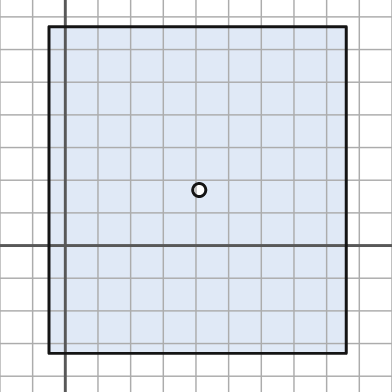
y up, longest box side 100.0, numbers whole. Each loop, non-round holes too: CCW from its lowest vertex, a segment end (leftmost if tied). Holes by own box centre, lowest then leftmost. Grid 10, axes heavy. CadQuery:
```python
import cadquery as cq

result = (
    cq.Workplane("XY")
    .moveTo(-5.0, -33.0)
    .lineTo(86.0, -33.0)
    .lineTo(86.0, 67.0)
    .lineTo(-5.0, 67.0)
    .close()
    .moveTo(41.0, 17.0)
    .circle(2.0)
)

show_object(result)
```